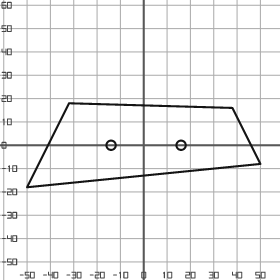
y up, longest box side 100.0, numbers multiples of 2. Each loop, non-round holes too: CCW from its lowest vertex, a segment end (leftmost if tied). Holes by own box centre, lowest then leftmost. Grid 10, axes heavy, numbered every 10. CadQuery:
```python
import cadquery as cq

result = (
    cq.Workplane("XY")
    .moveTo(-50.0, -18.0)
    .lineTo(50.0, -8.0)
    .lineTo(38.0, 16.0)
    .lineTo(-32.0, 18.0)
    .close()
    .moveTo(-14.0, 0.0)
    .circle(2.0)
    .moveTo(16.0, 0.0)
    .circle(2.0)
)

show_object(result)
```